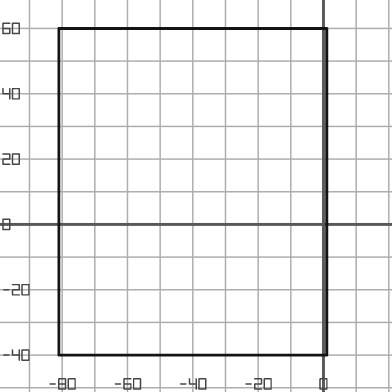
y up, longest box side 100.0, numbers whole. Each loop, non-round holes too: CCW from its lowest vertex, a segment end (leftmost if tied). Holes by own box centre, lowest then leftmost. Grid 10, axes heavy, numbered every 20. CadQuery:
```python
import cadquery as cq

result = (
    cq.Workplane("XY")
    .moveTo(-81.0, -40.0)
    .lineTo(1.0, -40.0)
    .lineTo(1.0, 60.0)
    .lineTo(-81.0, 60.0)
    .close()
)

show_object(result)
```